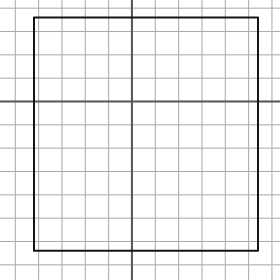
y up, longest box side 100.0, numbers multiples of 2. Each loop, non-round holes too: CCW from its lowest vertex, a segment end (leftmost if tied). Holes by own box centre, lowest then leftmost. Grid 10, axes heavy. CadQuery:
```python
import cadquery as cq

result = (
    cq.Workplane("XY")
    .moveTo(-42.0, -64.0)
    .lineTo(54.0, -64.0)
    .lineTo(54.0, 36.0)
    .lineTo(-42.0, 36.0)
    .close()
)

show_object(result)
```